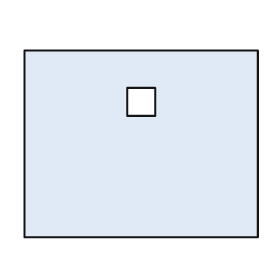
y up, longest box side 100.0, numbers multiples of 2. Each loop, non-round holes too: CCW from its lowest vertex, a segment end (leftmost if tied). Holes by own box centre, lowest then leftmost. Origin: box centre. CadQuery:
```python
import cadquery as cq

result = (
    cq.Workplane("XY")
    .moveTo(-50.0, -40.0)
    .lineTo(50.0, -40.0)
    .lineTo(50.0, 40.0)
    .lineTo(-50.0, 40.0)
    .close()
    .moveTo(-6.0, 12.0)
    .lineTo(6.0, 12.0)
    .lineTo(6.0, 24.0)
    .lineTo(-6.0, 24.0)
    .close()
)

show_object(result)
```